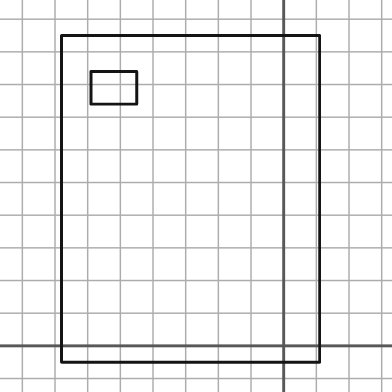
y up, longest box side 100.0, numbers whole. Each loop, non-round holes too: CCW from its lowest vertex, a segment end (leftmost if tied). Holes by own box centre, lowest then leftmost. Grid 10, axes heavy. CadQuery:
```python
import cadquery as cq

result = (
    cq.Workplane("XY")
    .moveTo(-68.0, -5.0)
    .lineTo(11.0, -5.0)
    .lineTo(11.0, 95.0)
    .lineTo(-68.0, 95.0)
    .close()
    .moveTo(-59.0, 74.0)
    .lineTo(-45.0, 74.0)
    .lineTo(-45.0, 84.0)
    .lineTo(-59.0, 84.0)
    .close()
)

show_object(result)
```